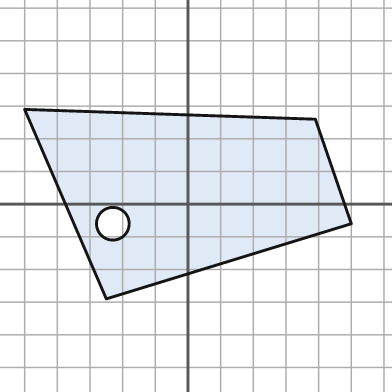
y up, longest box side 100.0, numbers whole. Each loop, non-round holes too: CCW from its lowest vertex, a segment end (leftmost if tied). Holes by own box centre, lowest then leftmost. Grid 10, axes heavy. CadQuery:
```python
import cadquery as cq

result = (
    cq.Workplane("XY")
    .moveTo(-25.0, -29.0)
    .lineTo(50.0, -6.0)
    .lineTo(39.0, 26.0)
    .lineTo(-50.0, 29.0)
    .close()
    .moveTo(-23.0, -6.0)
    .circle(5.0)
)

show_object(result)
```